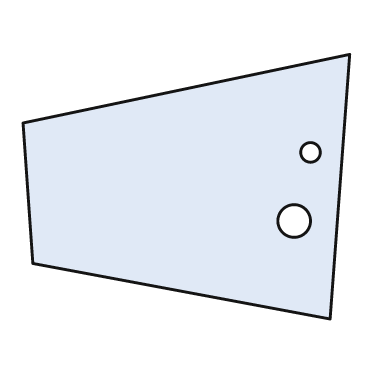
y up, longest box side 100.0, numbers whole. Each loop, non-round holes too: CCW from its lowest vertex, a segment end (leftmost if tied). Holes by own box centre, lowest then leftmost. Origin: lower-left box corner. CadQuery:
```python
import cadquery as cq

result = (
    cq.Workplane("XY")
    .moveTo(94.0, 0.0)
    .lineTo(100.0, 81.0)
    .lineTo(0.0, 60.0)
    .lineTo(3.0, 17.0)
    .close()
    .moveTo(83.0, 30.0)
    .circle(5.0)
    .moveTo(88.0, 51.0)
    .circle(3.0)
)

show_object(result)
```